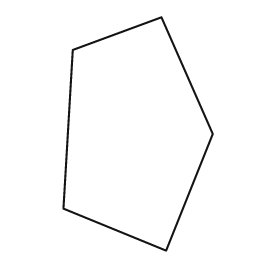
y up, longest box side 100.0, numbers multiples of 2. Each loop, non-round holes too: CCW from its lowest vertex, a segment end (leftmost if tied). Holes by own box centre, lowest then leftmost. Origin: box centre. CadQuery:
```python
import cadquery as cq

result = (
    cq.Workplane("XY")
    .moveTo(12.0, -50.0)
    .lineTo(32.0, 0.0)
    .lineTo(10.0, 50.0)
    .lineTo(-28.0, 36.0)
    .lineTo(-32.0, -32.0)
    .close()
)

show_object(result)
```